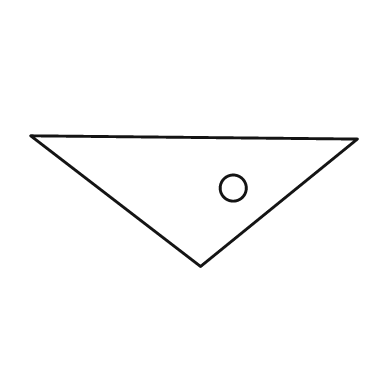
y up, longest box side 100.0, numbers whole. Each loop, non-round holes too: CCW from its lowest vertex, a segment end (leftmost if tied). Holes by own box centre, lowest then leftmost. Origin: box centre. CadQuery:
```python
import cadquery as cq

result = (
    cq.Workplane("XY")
    .moveTo(2.0, -20.0)
    .lineTo(50.0, 19.0)
    .lineTo(-50.0, 20.0)
    .close()
    .moveTo(12.0, 4.0)
    .circle(4.0)
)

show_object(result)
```